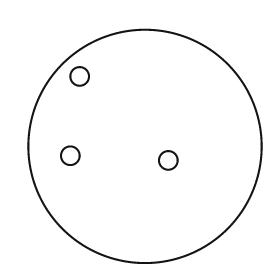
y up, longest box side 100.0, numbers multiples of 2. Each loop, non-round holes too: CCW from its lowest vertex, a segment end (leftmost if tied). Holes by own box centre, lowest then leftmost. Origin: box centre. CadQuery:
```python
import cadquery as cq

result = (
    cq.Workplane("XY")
    .moveTo(0.0, 0.0)
    .circle(50.0)
    .moveTo(10.0, -6.0)
    .circle(4.0)
    .moveTo(-32.0, -4.0)
    .circle(4.0)
    .moveTo(-28.0, 30.0)
    .circle(4.0)
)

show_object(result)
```